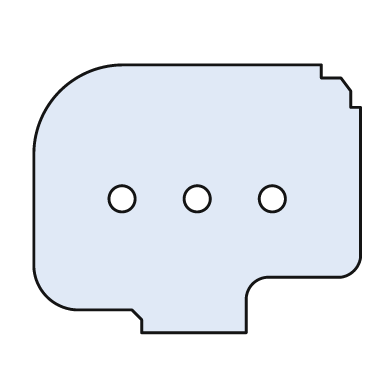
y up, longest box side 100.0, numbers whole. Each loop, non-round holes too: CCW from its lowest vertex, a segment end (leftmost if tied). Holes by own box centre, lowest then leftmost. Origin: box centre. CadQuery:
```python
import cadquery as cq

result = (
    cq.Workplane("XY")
    .moveTo(-17.0, -41.0)
    .lineTo(15.0, -41.0)
    .lineTo(15.0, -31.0)
    .threePointArc((17.0, -26.0), (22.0, -24.0))
    .lineTo(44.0, -24.0)
    .threePointArc((48.0, -22.0), (50.0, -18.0))
    .lineTo(50.0, 28.0)
    .lineTo(47.0, 28.0)
    .lineTo(47.0, 33.0)
    .lineTo(44.0, 37.0)
    .lineTo(38.0, 37.0)
    .lineTo(38.0, 41.0)
    .lineTo(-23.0, 41.0)
    .threePointArc((-42.0, 33.0), (-50.0, 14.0))
    .lineTo(-50.0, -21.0)
    .threePointArc((-46.0, -30.0), (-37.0, -34.0))
    .lineTo(-20.0, -34.0)
    .lineTo(-17.0, -37.0)
    .close()
    .moveTo(-23.0, 0.0)
    .circle(4.0)
    .moveTo(0.0, 0.0)
    .circle(4.0)
    .moveTo(23.0, 0.0)
    .circle(4.0)
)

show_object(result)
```